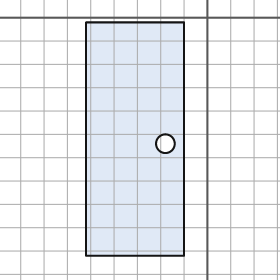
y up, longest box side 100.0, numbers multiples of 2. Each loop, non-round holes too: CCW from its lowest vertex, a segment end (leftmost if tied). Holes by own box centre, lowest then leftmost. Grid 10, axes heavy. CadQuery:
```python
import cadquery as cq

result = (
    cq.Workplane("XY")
    .moveTo(-52.0, -102.0)
    .lineTo(-10.0, -102.0)
    .lineTo(-10.0, -2.0)
    .lineTo(-52.0, -2.0)
    .close()
    .moveTo(-18.0, -54.0)
    .circle(4.0)
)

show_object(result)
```